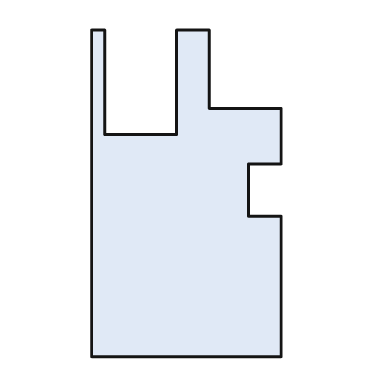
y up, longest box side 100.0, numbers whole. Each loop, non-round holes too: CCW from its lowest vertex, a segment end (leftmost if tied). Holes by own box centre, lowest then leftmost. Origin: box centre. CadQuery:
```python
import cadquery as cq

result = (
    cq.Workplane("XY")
    .moveTo(-29.0, -50.0)
    .lineTo(29.0, -50.0)
    .lineTo(29.0, -7.0)
    .lineTo(19.0, -7.0)
    .lineTo(19.0, 9.0)
    .lineTo(29.0, 9.0)
    .lineTo(29.0, 26.0)
    .lineTo(7.0, 26.0)
    .lineTo(7.0, 50.0)
    .lineTo(-3.0, 50.0)
    .lineTo(-3.0, 18.0)
    .lineTo(-25.0, 18.0)
    .lineTo(-25.0, 50.0)
    .lineTo(-29.0, 50.0)
    .close()
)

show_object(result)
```